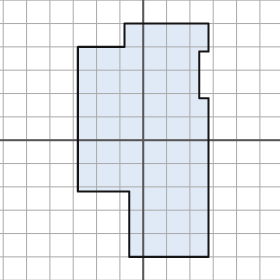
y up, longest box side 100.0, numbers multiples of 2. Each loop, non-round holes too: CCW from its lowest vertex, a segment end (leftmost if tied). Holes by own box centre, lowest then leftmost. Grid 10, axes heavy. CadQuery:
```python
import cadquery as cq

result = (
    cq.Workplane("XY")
    .moveTo(-6.0, -50.0)
    .lineTo(28.0, -50.0)
    .lineTo(28.0, 18.0)
    .lineTo(24.0, 18.0)
    .lineTo(24.0, 38.0)
    .lineTo(28.0, 38.0)
    .lineTo(28.0, 50.0)
    .lineTo(-8.0, 50.0)
    .lineTo(-8.0, 40.0)
    .lineTo(-28.0, 40.0)
    .lineTo(-28.0, -22.0)
    .lineTo(-6.0, -22.0)
    .close()
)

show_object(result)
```